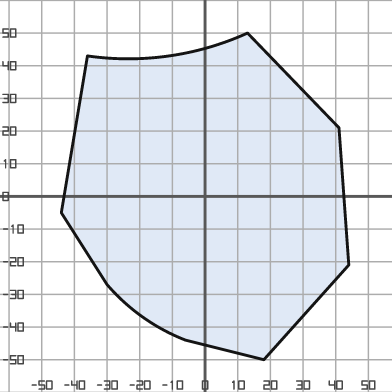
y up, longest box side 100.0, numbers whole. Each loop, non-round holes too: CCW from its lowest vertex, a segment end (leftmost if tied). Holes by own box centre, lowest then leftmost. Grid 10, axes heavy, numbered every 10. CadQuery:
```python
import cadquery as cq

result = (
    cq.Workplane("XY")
    .moveTo(18.0, -50.0)
    .lineTo(44.0, -21.0)
    .lineTo(41.0, 21.0)
    .lineTo(13.0, 50.0)
    .threePointArc((-11.0, 43.0), (-36.0, 43.0))
    .lineTo(-44.0, -5.0)
    .lineTo(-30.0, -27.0)
    .threePointArc((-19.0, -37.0), (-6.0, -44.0))
    .close()
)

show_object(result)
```